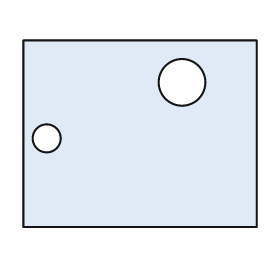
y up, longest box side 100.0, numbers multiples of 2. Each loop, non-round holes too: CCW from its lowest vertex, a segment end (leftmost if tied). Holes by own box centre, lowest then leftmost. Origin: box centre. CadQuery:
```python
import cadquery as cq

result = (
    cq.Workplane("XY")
    .moveTo(-50.0, -40.0)
    .lineTo(50.0, -40.0)
    .lineTo(50.0, 40.0)
    .lineTo(-50.0, 40.0)
    .close()
    .moveTo(-40.0, -2.0)
    .circle(6.0)
    .moveTo(18.0, 22.0)
    .circle(10.0)
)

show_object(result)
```